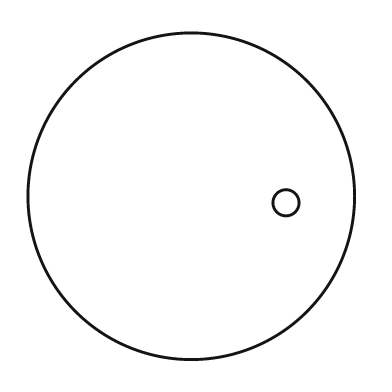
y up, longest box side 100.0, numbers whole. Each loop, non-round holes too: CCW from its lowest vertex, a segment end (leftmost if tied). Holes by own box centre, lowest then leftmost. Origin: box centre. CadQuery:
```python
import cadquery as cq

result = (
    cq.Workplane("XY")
    .moveTo(0.0, 0.0)
    .circle(50.0)
    .moveTo(29.0, -2.0)
    .circle(4.0)
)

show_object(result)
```